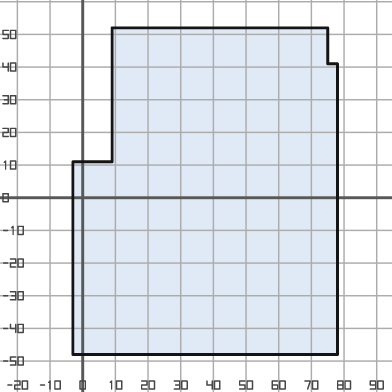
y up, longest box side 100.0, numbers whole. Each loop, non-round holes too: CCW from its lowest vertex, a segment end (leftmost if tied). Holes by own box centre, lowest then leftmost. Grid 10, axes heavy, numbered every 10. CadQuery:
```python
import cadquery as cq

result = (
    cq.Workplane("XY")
    .moveTo(-3.0, -48.0)
    .lineTo(78.0, -48.0)
    .lineTo(78.0, 41.0)
    .lineTo(75.0, 41.0)
    .lineTo(75.0, 52.0)
    .lineTo(9.0, 52.0)
    .lineTo(9.0, 11.0)
    .lineTo(-3.0, 11.0)
    .close()
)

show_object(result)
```